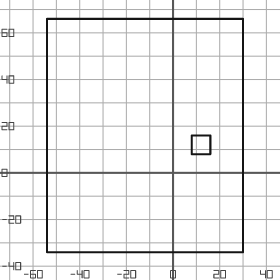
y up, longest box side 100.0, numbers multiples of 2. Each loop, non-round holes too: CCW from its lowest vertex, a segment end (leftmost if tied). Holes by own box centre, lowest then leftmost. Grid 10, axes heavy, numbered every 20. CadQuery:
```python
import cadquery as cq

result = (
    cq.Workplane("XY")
    .moveTo(-54.0, -34.0)
    .lineTo(30.0, -34.0)
    .lineTo(30.0, 66.0)
    .lineTo(-54.0, 66.0)
    .close()
    .moveTo(8.0, 8.0)
    .lineTo(16.0, 8.0)
    .lineTo(16.0, 16.0)
    .lineTo(8.0, 16.0)
    .close()
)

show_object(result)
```